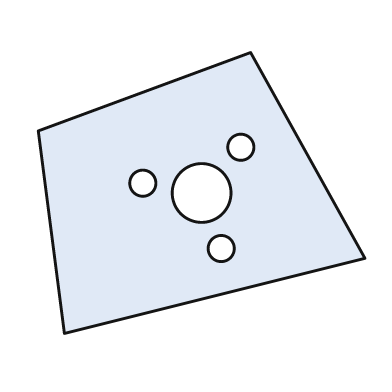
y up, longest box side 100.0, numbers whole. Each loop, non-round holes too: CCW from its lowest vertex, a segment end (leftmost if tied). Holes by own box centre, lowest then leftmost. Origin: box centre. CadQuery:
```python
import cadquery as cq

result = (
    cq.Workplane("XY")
    .moveTo(-42.0, -43.0)
    .lineTo(50.0, -20.0)
    .lineTo(15.0, 43.0)
    .lineTo(-50.0, 19.0)
    .close()
    .moveTo(6.0, -17.0)
    .circle(4.0)
    .moveTo(0.0, 0.0)
    .circle(9.0)
    .moveTo(-18.0, 3.0)
    .circle(4.0)
    .moveTo(12.0, 14.0)
    .circle(4.0)
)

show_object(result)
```